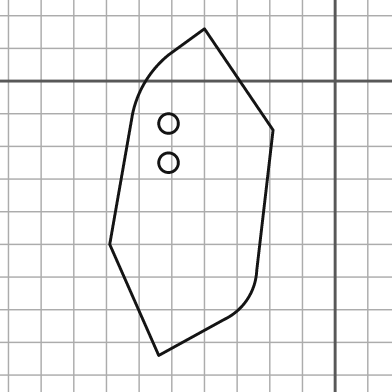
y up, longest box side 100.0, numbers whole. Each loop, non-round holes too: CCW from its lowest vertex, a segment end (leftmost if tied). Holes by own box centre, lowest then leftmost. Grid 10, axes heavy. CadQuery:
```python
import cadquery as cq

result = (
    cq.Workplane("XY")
    .moveTo(-54.0, -84.0)
    .lineTo(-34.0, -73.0)
    .threePointArc((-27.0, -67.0), (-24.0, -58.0))
    .lineTo(-19.0, -15.0)
    .lineTo(-40.0, 16.0)
    .lineTo(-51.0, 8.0)
    .threePointArc((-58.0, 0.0), (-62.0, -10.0))
    .lineTo(-69.0, -50.0)
    .close()
    .moveTo(-51.0, -25.0)
    .circle(3.0)
    .moveTo(-51.0, -13.0)
    .circle(3.0)
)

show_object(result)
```